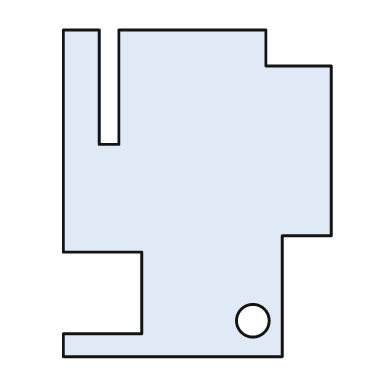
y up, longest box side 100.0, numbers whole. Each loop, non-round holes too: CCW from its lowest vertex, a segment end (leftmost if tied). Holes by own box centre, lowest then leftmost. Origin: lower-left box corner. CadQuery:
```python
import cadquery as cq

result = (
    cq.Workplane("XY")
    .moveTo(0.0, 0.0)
    .lineTo(67.0, 0.0)
    .lineTo(67.0, 37.0)
    .lineTo(82.0, 37.0)
    .lineTo(82.0, 89.0)
    .lineTo(62.0, 89.0)
    .lineTo(62.0, 100.0)
    .lineTo(17.0, 100.0)
    .lineTo(17.0, 65.0)
    .lineTo(11.0, 65.0)
    .lineTo(11.0, 100.0)
    .lineTo(0.0, 100.0)
    .lineTo(0.0, 32.0)
    .lineTo(24.0, 32.0)
    .lineTo(24.0, 7.0)
    .lineTo(0.0, 7.0)
    .close()
    .moveTo(58.0, 11.0)
    .circle(5.0)
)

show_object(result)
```